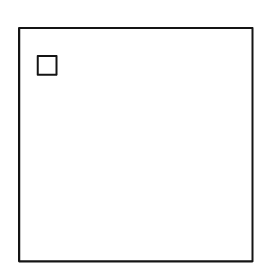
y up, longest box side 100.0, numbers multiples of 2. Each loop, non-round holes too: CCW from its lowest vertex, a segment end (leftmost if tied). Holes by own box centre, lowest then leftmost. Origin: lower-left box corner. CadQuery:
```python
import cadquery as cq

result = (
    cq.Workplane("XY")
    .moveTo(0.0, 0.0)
    .lineTo(100.0, 0.0)
    .lineTo(100.0, 100.0)
    .lineTo(0.0, 100.0)
    .close()
    .moveTo(8.0, 80.0)
    .lineTo(16.0, 80.0)
    .lineTo(16.0, 88.0)
    .lineTo(8.0, 88.0)
    .close()
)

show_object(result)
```